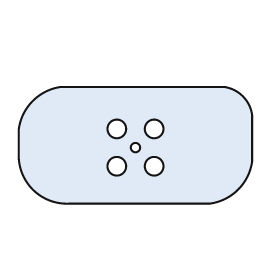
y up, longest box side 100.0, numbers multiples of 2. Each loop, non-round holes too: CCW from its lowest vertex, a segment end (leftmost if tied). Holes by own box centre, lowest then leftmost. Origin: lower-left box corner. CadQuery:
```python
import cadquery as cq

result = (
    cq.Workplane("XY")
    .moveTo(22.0, 0.0)
    .lineTo(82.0, 0.0)
    .threePointArc((94.0, 6.0), (100.0, 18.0))
    .lineTo(100.0, 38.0)
    .threePointArc((96.0, 46.0), (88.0, 50.0))
    .lineTo(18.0, 50.0)
    .threePointArc((6.0, 44.0), (0.0, 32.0))
    .lineTo(0.0, 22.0)
    .threePointArc((6.0, 6.0), (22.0, 0.0))
    .close()
    .moveTo(42.0, 16.0)
    .circle(4.0)
    .moveTo(58.0, 16.0)
    .circle(4.0)
    .moveTo(50.0, 24.0)
    .circle(2.0)
    .moveTo(42.0, 32.0)
    .circle(4.0)
    .moveTo(58.0, 32.0)
    .circle(4.0)
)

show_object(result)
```